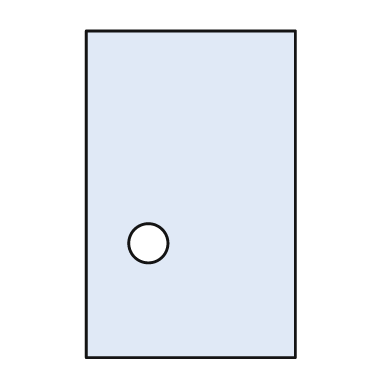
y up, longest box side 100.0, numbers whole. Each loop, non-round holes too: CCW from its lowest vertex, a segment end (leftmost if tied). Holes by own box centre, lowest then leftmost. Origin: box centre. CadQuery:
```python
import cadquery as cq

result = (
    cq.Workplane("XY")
    .moveTo(-32.0, -50.0)
    .lineTo(32.0, -50.0)
    .lineTo(32.0, 50.0)
    .lineTo(-32.0, 50.0)
    .close()
    .moveTo(-13.0, -15.0)
    .circle(6.0)
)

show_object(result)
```